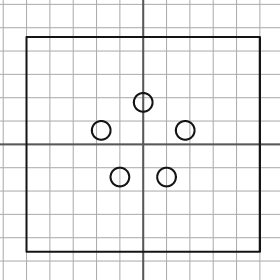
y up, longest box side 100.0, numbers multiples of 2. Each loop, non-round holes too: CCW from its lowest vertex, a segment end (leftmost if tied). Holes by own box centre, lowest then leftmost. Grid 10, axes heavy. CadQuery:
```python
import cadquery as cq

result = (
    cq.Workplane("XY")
    .moveTo(-50.0, -46.0)
    .lineTo(50.0, -46.0)
    .lineTo(50.0, 46.0)
    .lineTo(-50.0, 46.0)
    .close()
    .moveTo(-10.0, -14.0)
    .circle(4.0)
    .moveTo(10.0, -14.0)
    .circle(4.0)
    .moveTo(-18.0, 6.0)
    .circle(4.0)
    .moveTo(18.0, 6.0)
    .circle(4.0)
    .moveTo(0.0, 18.0)
    .circle(4.0)
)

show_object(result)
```